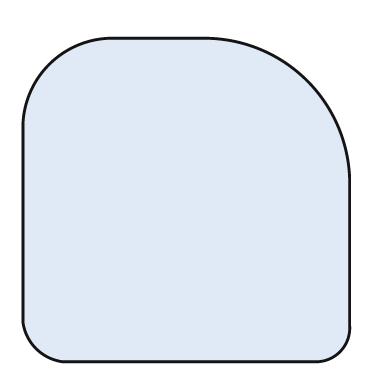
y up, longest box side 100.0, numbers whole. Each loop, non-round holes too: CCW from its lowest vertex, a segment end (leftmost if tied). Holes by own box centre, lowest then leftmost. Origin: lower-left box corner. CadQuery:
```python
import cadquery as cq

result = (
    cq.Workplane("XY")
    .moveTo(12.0, 0.0)
    .lineTo(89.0, 0.0)
    .threePointArc((97.0, 3.0), (100.0, 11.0))
    .lineTo(100.0, 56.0)
    .threePointArc((87.0, 86.0), (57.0, 99.0))
    .lineTo(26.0, 99.0)
    .threePointArc((8.0, 91.0), (0.0, 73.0))
    .lineTo(0.0, 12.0)
    .threePointArc((4.0, 4.0), (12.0, 0.0))
    .close()
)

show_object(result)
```